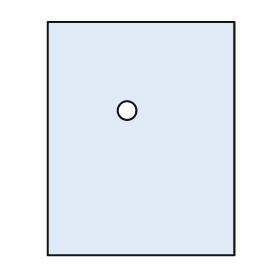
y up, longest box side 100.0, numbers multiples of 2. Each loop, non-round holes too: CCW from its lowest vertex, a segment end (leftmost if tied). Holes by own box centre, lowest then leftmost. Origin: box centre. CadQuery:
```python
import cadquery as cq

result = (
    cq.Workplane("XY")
    .moveTo(-40.0, -50.0)
    .lineTo(40.0, -50.0)
    .lineTo(40.0, 50.0)
    .lineTo(-40.0, 50.0)
    .close()
    .moveTo(-6.0, 12.0)
    .circle(4.0)
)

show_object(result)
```